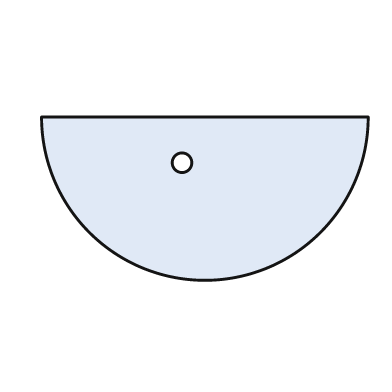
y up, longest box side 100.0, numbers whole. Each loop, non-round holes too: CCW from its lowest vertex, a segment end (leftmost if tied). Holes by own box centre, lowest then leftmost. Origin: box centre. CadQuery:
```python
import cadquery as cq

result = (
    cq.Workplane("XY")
    .moveTo(-50.0, 25.0)
    .threePointArc((0.0, -25.0), (50.0, 25.0))
    .close()
    .moveTo(-7.0, 11.0)
    .circle(3.0)
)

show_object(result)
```